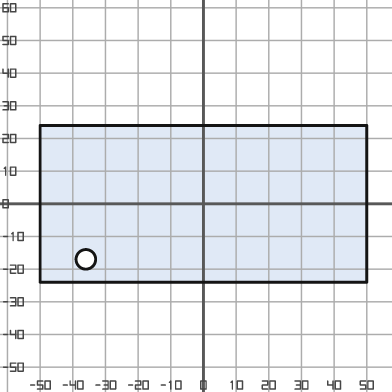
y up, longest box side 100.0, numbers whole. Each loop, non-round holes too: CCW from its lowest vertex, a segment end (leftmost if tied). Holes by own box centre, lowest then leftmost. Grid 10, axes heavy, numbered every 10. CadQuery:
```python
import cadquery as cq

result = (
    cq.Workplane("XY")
    .moveTo(-50.0, -24.0)
    .lineTo(50.0, -24.0)
    .lineTo(50.0, 24.0)
    .lineTo(-50.0, 24.0)
    .close()
    .moveTo(-36.0, -17.0)
    .circle(3.0)
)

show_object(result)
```